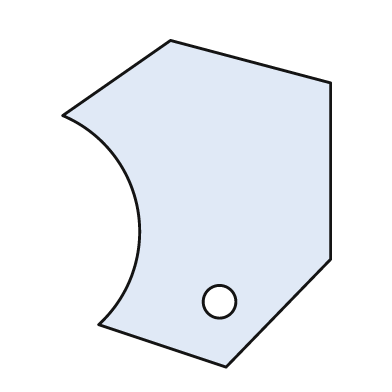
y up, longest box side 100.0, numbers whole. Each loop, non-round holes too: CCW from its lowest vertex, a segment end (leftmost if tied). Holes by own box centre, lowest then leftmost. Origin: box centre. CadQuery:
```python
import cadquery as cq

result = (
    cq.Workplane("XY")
    .moveTo(9.0, -50.0)
    .lineTo(41.0, -17.0)
    .lineTo(41.0, 37.0)
    .lineTo(-8.0, 50.0)
    .lineTo(-41.0, 27.0)
    .threePointArc((-18.0, -2.0), (-30.0, -37.0))
    .close()
    .moveTo(7.0, -30.0)
    .circle(5.0)
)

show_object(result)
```